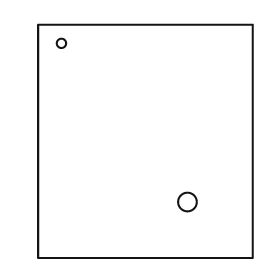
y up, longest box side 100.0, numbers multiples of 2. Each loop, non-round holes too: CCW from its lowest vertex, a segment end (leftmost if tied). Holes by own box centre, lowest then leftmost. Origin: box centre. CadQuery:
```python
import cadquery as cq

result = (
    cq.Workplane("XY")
    .moveTo(-46.0, -50.0)
    .lineTo(46.0, -50.0)
    .lineTo(46.0, 50.0)
    .lineTo(-46.0, 50.0)
    .close()
    .moveTo(18.0, -26.0)
    .circle(4.0)
    .moveTo(-36.0, 42.0)
    .circle(2.0)
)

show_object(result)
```